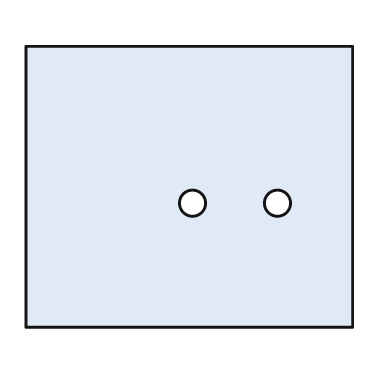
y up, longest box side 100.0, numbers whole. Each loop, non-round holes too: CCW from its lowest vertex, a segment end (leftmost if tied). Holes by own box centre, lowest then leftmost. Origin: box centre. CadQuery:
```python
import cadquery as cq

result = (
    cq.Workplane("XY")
    .moveTo(-50.0, -43.0)
    .lineTo(50.0, -43.0)
    .lineTo(50.0, 43.0)
    .lineTo(-50.0, 43.0)
    .close()
    .moveTo(1.0, -5.0)
    .circle(4.0)
    .moveTo(27.0, -5.0)
    .circle(4.0)
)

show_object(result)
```